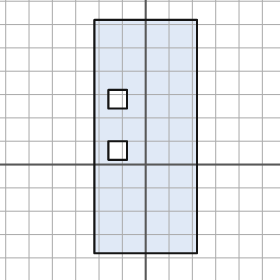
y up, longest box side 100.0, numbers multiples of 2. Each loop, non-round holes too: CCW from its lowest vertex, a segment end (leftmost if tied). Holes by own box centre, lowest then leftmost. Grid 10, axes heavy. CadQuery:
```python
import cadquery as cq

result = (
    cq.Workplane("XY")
    .moveTo(-22.0, -38.0)
    .lineTo(22.0, -38.0)
    .lineTo(22.0, 62.0)
    .lineTo(-22.0, 62.0)
    .close()
    .moveTo(-16.0, 2.0)
    .lineTo(-8.0, 2.0)
    .lineTo(-8.0, 10.0)
    .lineTo(-16.0, 10.0)
    .close()
    .moveTo(-16.0, 24.0)
    .lineTo(-8.0, 24.0)
    .lineTo(-8.0, 32.0)
    .lineTo(-16.0, 32.0)
    .close()
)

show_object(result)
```